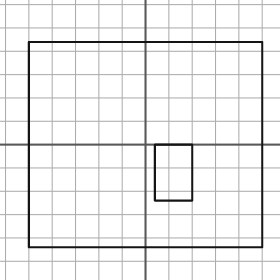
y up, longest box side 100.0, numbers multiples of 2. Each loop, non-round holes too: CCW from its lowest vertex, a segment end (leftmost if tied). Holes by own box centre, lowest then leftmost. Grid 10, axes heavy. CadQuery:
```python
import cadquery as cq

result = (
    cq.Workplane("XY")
    .moveTo(-50.0, -44.0)
    .lineTo(50.0, -44.0)
    .lineTo(50.0, 44.0)
    .lineTo(-50.0, 44.0)
    .close()
    .moveTo(4.0, -24.0)
    .lineTo(20.0, -24.0)
    .lineTo(20.0, 0.0)
    .lineTo(4.0, 0.0)
    .close()
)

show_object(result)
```